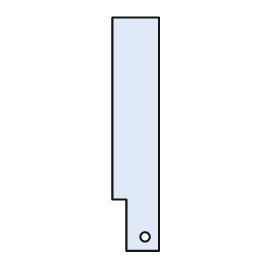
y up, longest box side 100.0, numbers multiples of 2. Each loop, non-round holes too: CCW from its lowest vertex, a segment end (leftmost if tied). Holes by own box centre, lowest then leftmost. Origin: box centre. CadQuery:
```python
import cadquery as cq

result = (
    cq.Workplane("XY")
    .moveTo(-4.0, -50.0)
    .lineTo(10.0, -50.0)
    .lineTo(10.0, 50.0)
    .lineTo(-10.0, 50.0)
    .lineTo(-10.0, -28.0)
    .lineTo(-4.0, -28.0)
    .close()
    .moveTo(4.0, -44.0)
    .circle(2.0)
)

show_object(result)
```